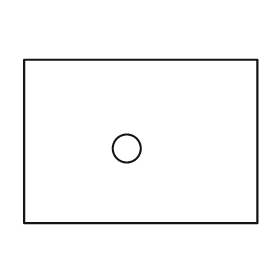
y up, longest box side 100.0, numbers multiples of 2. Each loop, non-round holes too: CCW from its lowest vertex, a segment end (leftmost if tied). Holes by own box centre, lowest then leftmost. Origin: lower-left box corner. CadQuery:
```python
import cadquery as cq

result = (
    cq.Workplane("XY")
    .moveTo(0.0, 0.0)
    .lineTo(100.0, 0.0)
    .lineTo(100.0, 70.0)
    .lineTo(0.0, 70.0)
    .close()
    .moveTo(44.0, 32.0)
    .circle(6.0)
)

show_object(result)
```